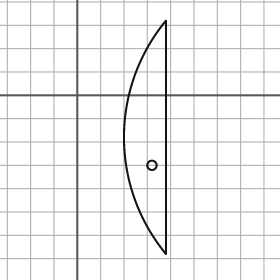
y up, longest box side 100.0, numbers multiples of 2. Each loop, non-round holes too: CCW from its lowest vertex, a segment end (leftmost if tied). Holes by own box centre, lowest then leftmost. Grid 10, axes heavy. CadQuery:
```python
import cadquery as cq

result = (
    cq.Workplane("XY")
    .moveTo(38.0, -68.0)
    .lineTo(38.0, 32.0)
    .threePointArc((20.0, -18.0), (38.0, -68.0))
    .close()
    .moveTo(32.0, -30.0)
    .circle(2.0)
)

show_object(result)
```